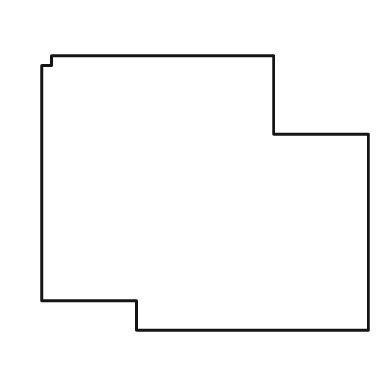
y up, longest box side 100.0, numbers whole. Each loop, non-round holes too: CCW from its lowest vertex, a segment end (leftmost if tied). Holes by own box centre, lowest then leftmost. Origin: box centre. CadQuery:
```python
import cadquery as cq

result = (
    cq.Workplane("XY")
    .moveTo(-21.0, -42.0)
    .lineTo(50.0, -42.0)
    .lineTo(50.0, 18.0)
    .lineTo(21.0, 18.0)
    .lineTo(21.0, 42.0)
    .lineTo(-47.0, 42.0)
    .lineTo(-47.0, 39.0)
    .lineTo(-50.0, 39.0)
    .lineTo(-50.0, -33.0)
    .lineTo(-21.0, -33.0)
    .close()
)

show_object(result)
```